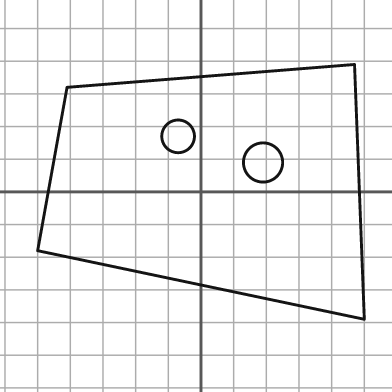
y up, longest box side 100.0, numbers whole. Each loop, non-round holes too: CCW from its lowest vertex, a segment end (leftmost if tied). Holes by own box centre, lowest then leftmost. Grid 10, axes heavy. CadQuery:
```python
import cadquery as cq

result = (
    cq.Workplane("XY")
    .moveTo(50.0, -39.0)
    .lineTo(47.0, 39.0)
    .lineTo(-41.0, 32.0)
    .lineTo(-50.0, -18.0)
    .close()
    .moveTo(19.0, 9.0)
    .circle(6.0)
    .moveTo(-7.0, 17.0)
    .circle(5.0)
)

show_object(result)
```